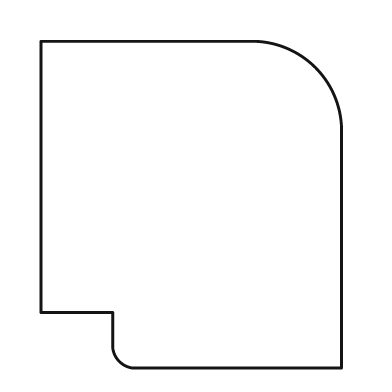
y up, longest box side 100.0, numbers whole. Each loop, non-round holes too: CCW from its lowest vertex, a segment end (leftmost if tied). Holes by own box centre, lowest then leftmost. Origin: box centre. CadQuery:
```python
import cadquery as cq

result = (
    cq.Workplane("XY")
    .moveTo(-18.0, -50.0)
    .lineTo(46.0, -50.0)
    .lineTo(46.0, 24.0)
    .threePointArc((38.0, 42.0), (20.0, 50.0))
    .lineTo(-46.0, 50.0)
    .lineTo(-46.0, -33.0)
    .lineTo(-24.0, -33.0)
    .lineTo(-24.0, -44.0)
    .threePointArc((-22.0, -48.0), (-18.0, -50.0))
    .close()
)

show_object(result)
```